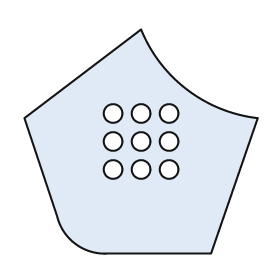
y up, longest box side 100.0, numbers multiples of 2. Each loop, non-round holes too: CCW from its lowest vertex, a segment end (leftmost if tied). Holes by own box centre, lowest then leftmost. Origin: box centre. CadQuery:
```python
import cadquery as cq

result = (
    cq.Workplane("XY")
    .moveTo(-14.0, -48.0)
    .lineTo(30.0, -48.0)
    .lineTo(50.0, 10.0)
    .threePointArc((20.0, 22.0), (0.0, 48.0))
    .lineTo(-50.0, 10.0)
    .lineTo(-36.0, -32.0)
    .threePointArc((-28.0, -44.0), (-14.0, -48.0))
    .close()
    .moveTo(-12.0, -12.0)
    .circle(4.0)
    .moveTo(0.0, -12.0)
    .circle(4.0)
    .moveTo(12.0, -12.0)
    .circle(4.0)
    .moveTo(-12.0, 0.0)
    .circle(4.0)
    .moveTo(0.0, 0.0)
    .circle(4.0)
    .moveTo(12.0, 0.0)
    .circle(4.0)
    .moveTo(-12.0, 12.0)
    .circle(4.0)
    .moveTo(0.0, 12.0)
    .circle(4.0)
    .moveTo(12.0, 12.0)
    .circle(4.0)
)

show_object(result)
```